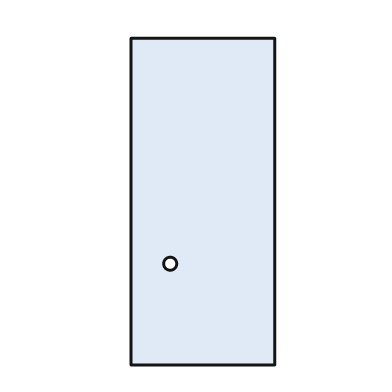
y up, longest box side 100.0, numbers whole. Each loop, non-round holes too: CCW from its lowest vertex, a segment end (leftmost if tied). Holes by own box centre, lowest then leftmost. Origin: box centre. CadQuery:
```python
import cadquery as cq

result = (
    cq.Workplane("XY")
    .moveTo(-22.0, -50.0)
    .lineTo(22.0, -50.0)
    .lineTo(22.0, 50.0)
    .lineTo(-22.0, 50.0)
    .close()
    .moveTo(-10.0, -19.0)
    .circle(2.0)
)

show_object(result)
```